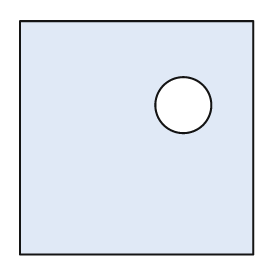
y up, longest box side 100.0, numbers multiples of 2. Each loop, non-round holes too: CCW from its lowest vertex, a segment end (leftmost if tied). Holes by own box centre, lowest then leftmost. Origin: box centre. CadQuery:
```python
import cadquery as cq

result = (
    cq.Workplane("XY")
    .moveTo(-50.0, -50.0)
    .lineTo(50.0, -50.0)
    .lineTo(50.0, 50.0)
    .lineTo(-50.0, 50.0)
    .close()
    .moveTo(20.0, 14.0)
    .circle(12.0)
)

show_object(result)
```